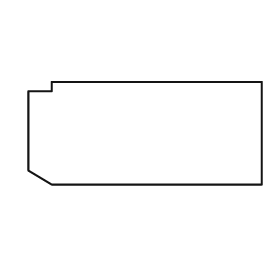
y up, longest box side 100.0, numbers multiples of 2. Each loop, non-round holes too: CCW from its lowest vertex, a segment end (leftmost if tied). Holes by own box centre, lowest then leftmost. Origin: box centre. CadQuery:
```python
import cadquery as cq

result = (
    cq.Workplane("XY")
    .moveTo(-40.0, -22.0)
    .lineTo(50.0, -22.0)
    .lineTo(50.0, 22.0)
    .lineTo(-40.0, 22.0)
    .lineTo(-40.0, 18.0)
    .lineTo(-50.0, 18.0)
    .lineTo(-50.0, -16.0)
    .close()
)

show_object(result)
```